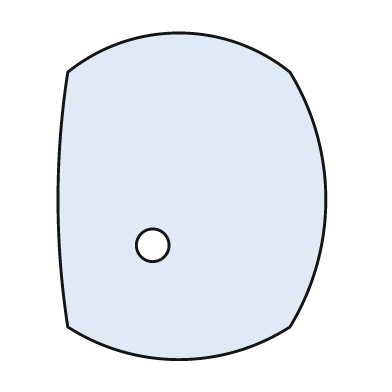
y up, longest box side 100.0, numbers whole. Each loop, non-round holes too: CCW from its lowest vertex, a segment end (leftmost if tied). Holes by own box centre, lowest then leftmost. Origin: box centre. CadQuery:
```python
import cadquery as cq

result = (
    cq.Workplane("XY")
    .moveTo(-38.0, -40.0)
    .threePointArc((-4.0, -50.0), (30.0, -40.0))
    .threePointArc((41.0, -1.0), (30.0, 38.0))
    .threePointArc((-4.0, 50.0), (-38.0, 38.0))
    .threePointArc((-41.0, -1.0), (-38.0, -40.0))
    .close()
    .moveTo(-12.0, -15.0)
    .circle(5.0)
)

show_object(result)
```